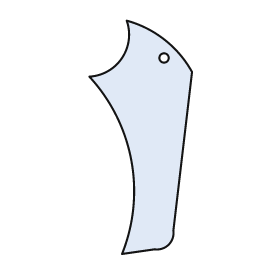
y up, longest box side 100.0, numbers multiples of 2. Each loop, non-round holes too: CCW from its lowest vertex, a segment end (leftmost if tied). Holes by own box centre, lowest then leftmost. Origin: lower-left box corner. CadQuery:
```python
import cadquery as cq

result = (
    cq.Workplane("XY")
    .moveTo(14.0, 0.0)
    .lineTo(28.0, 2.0)
    .threePointArc((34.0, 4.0), (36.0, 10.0))
    .lineTo(44.0, 78.0)
    .threePointArc((32.0, 92.0), (16.0, 100.0))
    .threePointArc((14.0, 84.0), (0.0, 76.0))
    .threePointArc((18.0, 40.0), (14.0, 0.0))
    .close()
    .moveTo(32.0, 84.0)
    .circle(2.0)
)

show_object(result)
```